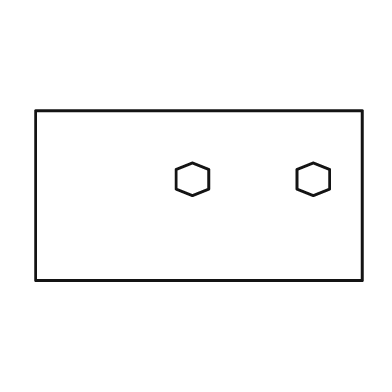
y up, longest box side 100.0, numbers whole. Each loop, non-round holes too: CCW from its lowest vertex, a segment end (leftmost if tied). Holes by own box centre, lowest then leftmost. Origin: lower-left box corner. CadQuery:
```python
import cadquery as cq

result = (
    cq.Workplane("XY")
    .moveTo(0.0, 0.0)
    .lineTo(100.0, 0.0)
    .lineTo(100.0, 52.0)
    .lineTo(0.0, 52.0)
    .close()
    .moveTo(48.0, 26.0)
    .lineTo(53.0, 28.0)
    .lineTo(53.0, 34.0)
    .lineTo(48.0, 36.0)
    .lineTo(43.0, 34.0)
    .lineTo(43.0, 28.0)
    .close()
    .moveTo(85.0, 26.0)
    .lineTo(90.0, 28.0)
    .lineTo(90.0, 34.0)
    .lineTo(85.0, 36.0)
    .lineTo(80.0, 34.0)
    .lineTo(80.0, 28.0)
    .close()
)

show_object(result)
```